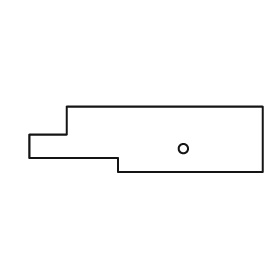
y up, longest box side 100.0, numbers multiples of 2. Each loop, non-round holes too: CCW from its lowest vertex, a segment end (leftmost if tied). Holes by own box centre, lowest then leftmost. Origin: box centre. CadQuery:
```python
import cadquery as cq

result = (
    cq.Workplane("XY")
    .moveTo(-12.0, -14.0)
    .lineTo(50.0, -14.0)
    .lineTo(50.0, 14.0)
    .lineTo(-34.0, 14.0)
    .lineTo(-34.0, 2.0)
    .lineTo(-50.0, 2.0)
    .lineTo(-50.0, -8.0)
    .lineTo(-12.0, -8.0)
    .close()
    .moveTo(16.0, -4.0)
    .circle(2.0)
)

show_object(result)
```